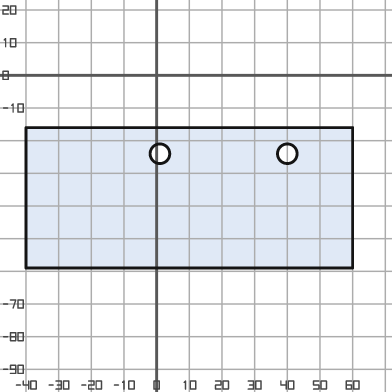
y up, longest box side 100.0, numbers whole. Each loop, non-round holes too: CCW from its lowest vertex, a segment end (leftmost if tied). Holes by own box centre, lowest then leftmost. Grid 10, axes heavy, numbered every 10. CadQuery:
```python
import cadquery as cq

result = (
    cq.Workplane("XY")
    .moveTo(-40.0, -59.0)
    .lineTo(60.0, -59.0)
    .lineTo(60.0, -16.0)
    .lineTo(-40.0, -16.0)
    .close()
    .moveTo(1.0, -24.0)
    .circle(3.0)
    .moveTo(40.0, -24.0)
    .circle(3.0)
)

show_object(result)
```